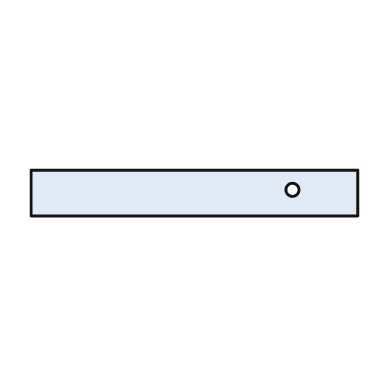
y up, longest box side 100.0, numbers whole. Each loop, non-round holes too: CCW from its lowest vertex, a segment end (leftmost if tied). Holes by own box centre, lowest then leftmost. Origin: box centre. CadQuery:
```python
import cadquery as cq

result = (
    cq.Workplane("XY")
    .moveTo(-50.0, -7.0)
    .lineTo(50.0, -7.0)
    .lineTo(50.0, 7.0)
    .lineTo(-50.0, 7.0)
    .close()
    .moveTo(30.0, 1.0)
    .circle(2.0)
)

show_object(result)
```